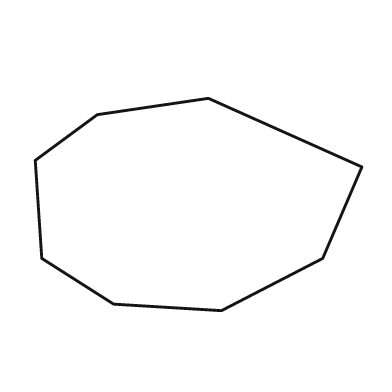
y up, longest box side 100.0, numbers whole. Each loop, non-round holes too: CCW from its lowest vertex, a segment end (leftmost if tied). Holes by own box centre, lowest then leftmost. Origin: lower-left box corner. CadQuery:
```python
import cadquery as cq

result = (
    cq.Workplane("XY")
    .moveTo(57.0, 0.0)
    .lineTo(88.0, 16.0)
    .lineTo(100.0, 44.0)
    .lineTo(53.0, 65.0)
    .lineTo(19.0, 60.0)
    .lineTo(0.0, 46.0)
    .lineTo(2.0, 16.0)
    .lineTo(24.0, 2.0)
    .close()
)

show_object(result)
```